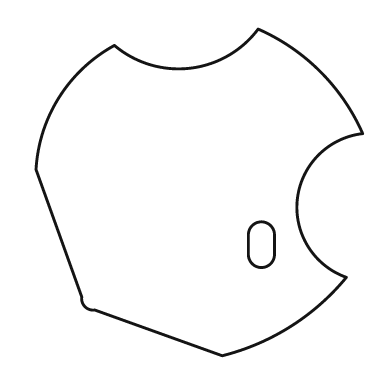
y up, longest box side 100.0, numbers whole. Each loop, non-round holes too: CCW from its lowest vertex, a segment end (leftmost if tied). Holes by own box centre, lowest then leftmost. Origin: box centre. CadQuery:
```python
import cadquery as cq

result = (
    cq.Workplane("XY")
    .moveTo(7.0, -50.0)
    .threePointArc((28.0, -41.0), (45.0, -26.0))
    .threePointArc((30.0, -2.0), (50.0, 18.0))
    .threePointArc((37.0, 37.0), (18.0, 50.0))
    .threePointArc((-3.0, 38.0), (-26.0, 45.0))
    .threePointArc((-43.0, 29.0), (-50.0, 7.0))
    .lineTo(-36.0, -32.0)
    .threePointArc((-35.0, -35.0), (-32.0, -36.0))
    .close()
    .moveTo(15.0, -19.0)
    .threePointArc((19.0, -23.0), (23.0, -19.0))
    .lineTo(23.0, -13.0)
    .threePointArc((19.0, -9.0), (15.0, -13.0))
    .close()
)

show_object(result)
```